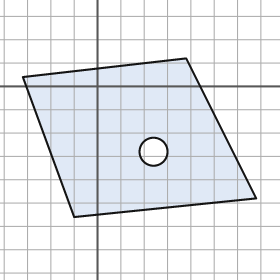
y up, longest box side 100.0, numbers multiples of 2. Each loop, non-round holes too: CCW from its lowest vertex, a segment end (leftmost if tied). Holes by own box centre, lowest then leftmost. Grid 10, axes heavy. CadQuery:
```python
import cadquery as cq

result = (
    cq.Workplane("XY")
    .moveTo(-10.0, -56.0)
    .lineTo(68.0, -48.0)
    .lineTo(38.0, 12.0)
    .lineTo(-32.0, 4.0)
    .close()
    .moveTo(24.0, -28.0)
    .circle(6.0)
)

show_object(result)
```